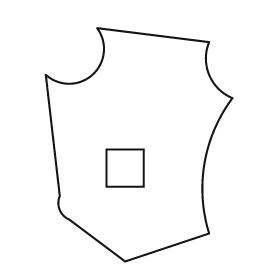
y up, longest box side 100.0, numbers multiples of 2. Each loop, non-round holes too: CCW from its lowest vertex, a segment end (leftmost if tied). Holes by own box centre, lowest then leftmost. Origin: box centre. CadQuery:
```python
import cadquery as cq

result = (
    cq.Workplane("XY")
    .moveTo(-6.0, -50.0)
    .lineTo(30.0, -38.0)
    .threePointArc((28.0, -8.0), (40.0, 20.0))
    .threePointArc((30.0, 30.0), (30.0, 44.0))
    .lineTo(-18.0, 50.0)
    .threePointArc((-20.0, 30.0), (-40.0, 30.0))
    .lineTo(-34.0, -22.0)
    .threePointArc((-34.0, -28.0), (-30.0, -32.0))
    .close()
    .moveTo(-14.0, -18.0)
    .lineTo(2.0, -18.0)
    .lineTo(2.0, -2.0)
    .lineTo(-14.0, -2.0)
    .close()
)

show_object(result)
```